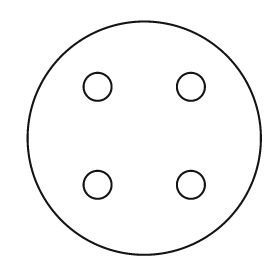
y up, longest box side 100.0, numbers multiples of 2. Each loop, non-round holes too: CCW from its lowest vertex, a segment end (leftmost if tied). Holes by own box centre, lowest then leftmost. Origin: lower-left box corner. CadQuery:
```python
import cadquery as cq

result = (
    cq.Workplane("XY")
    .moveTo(50.0, 50.0)
    .circle(50.0)
    .moveTo(30.0, 30.0)
    .circle(6.0)
    .moveTo(70.0, 30.0)
    .circle(6.0)
    .moveTo(30.0, 72.0)
    .circle(6.0)
    .moveTo(70.0, 72.0)
    .circle(6.0)
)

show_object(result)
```